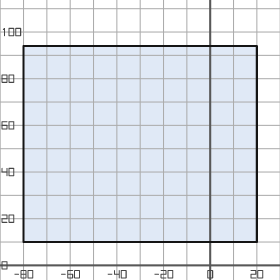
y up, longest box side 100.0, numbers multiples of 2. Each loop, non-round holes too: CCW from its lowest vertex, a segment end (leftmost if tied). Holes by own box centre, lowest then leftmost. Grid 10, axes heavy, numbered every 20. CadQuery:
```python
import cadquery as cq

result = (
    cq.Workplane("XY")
    .moveTo(-80.0, 10.0)
    .lineTo(20.0, 10.0)
    .lineTo(20.0, 94.0)
    .lineTo(-80.0, 94.0)
    .close()
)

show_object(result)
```